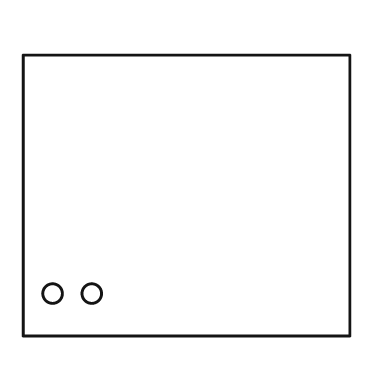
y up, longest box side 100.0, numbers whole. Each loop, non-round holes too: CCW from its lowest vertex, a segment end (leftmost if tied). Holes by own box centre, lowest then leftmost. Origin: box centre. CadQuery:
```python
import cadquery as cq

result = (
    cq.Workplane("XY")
    .moveTo(-50.0, -43.0)
    .lineTo(50.0, -43.0)
    .lineTo(50.0, 43.0)
    .lineTo(-50.0, 43.0)
    .close()
    .moveTo(-41.0, -30.0)
    .circle(3.0)
    .moveTo(-29.0, -30.0)
    .circle(3.0)
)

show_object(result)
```